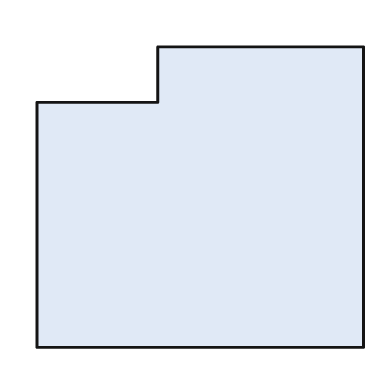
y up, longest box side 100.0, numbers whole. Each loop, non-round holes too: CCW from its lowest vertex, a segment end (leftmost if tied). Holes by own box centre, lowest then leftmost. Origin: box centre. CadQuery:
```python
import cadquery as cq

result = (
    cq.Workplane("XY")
    .moveTo(-50.0, -46.0)
    .lineTo(50.0, -46.0)
    .lineTo(50.0, 46.0)
    .lineTo(-13.0, 46.0)
    .lineTo(-13.0, 29.0)
    .lineTo(-50.0, 29.0)
    .close()
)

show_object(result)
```